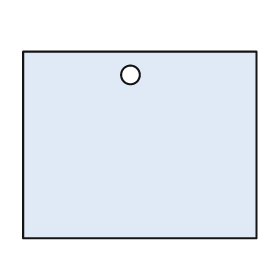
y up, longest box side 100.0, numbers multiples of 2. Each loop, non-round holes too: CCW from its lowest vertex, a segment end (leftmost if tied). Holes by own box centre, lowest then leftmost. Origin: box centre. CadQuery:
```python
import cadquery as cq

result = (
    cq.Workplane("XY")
    .moveTo(-50.0, -40.0)
    .lineTo(50.0, -40.0)
    .lineTo(50.0, 40.0)
    .lineTo(-50.0, 40.0)
    .close()
    .moveTo(-4.0, 30.0)
    .circle(4.0)
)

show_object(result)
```